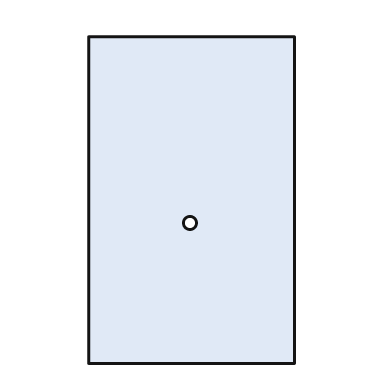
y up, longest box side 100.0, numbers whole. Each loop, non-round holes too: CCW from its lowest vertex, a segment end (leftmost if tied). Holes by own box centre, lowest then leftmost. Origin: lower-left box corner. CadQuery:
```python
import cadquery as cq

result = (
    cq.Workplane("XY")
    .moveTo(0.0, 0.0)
    .lineTo(63.0, 0.0)
    .lineTo(63.0, 100.0)
    .lineTo(0.0, 100.0)
    .close()
    .moveTo(31.0, 43.0)
    .circle(2.0)
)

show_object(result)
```